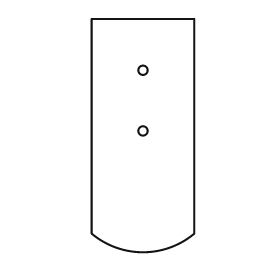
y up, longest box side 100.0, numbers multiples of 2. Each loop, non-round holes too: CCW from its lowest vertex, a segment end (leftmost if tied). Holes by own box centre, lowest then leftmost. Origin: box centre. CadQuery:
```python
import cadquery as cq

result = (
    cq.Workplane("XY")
    .moveTo(-22.0, -42.0)
    .threePointArc((0.0, -50.0), (22.0, -42.0))
    .lineTo(22.0, 50.0)
    .lineTo(-22.0, 50.0)
    .close()
    .moveTo(0.0, 2.0)
    .circle(2.0)
    .moveTo(0.0, 28.0)
    .circle(2.0)
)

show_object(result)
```